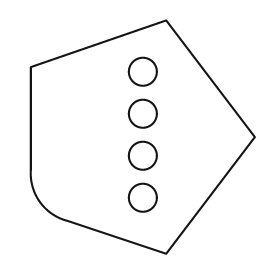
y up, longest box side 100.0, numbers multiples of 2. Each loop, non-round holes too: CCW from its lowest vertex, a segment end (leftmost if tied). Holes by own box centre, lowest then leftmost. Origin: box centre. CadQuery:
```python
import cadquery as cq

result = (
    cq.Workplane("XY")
    .moveTo(10.0, -50.0)
    .lineTo(48.0, 0.0)
    .lineTo(10.0, 50.0)
    .lineTo(-48.0, 30.0)
    .lineTo(-48.0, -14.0)
    .threePointArc((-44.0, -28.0), (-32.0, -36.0))
    .close()
    .moveTo(0.0, -26.0)
    .circle(6.0)
    .moveTo(0.0, -8.0)
    .circle(6.0)
    .moveTo(0.0, 10.0)
    .circle(6.0)
    .moveTo(0.0, 28.0)
    .circle(6.0)
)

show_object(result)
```